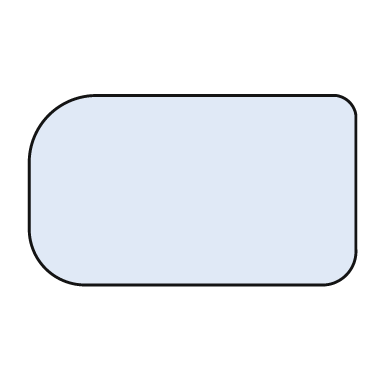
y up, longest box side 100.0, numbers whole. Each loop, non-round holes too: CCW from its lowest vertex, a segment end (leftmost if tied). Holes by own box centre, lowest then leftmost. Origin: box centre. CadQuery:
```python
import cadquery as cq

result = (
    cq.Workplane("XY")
    .moveTo(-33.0, -29.0)
    .lineTo(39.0, -29.0)
    .threePointArc((47.0, -26.0), (50.0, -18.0))
    .lineTo(50.0, 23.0)
    .threePointArc((48.0, 27.0), (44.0, 29.0))
    .lineTo(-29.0, 29.0)
    .threePointArc((-44.0, 23.0), (-50.0, 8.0))
    .lineTo(-50.0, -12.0)
    .threePointArc((-45.0, -24.0), (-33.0, -29.0))
    .close()
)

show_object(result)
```